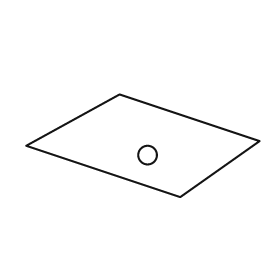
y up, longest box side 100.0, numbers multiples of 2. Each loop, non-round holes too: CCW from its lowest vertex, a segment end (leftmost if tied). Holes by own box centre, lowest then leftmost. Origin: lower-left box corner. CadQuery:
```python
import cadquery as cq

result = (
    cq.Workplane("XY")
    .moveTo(66.0, 0.0)
    .lineTo(100.0, 24.0)
    .lineTo(40.0, 44.0)
    .lineTo(0.0, 22.0)
    .close()
    .moveTo(52.0, 18.0)
    .circle(4.0)
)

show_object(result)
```